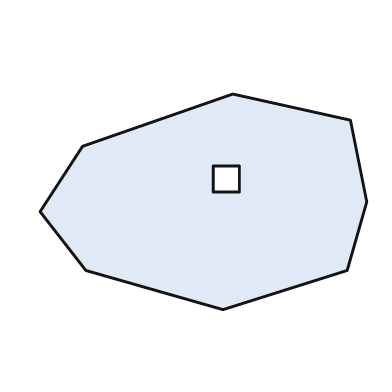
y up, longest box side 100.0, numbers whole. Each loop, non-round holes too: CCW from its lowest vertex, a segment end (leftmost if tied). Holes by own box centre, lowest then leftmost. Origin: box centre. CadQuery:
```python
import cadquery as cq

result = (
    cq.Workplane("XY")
    .moveTo(6.0, -33.0)
    .lineTo(44.0, -21.0)
    .lineTo(50.0, 0.0)
    .lineTo(45.0, 25.0)
    .lineTo(9.0, 33.0)
    .lineTo(-37.0, 17.0)
    .lineTo(-50.0, -3.0)
    .lineTo(-36.0, -21.0)
    .close()
    .moveTo(3.0, 3.0)
    .lineTo(11.0, 3.0)
    .lineTo(11.0, 11.0)
    .lineTo(3.0, 11.0)
    .close()
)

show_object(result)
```